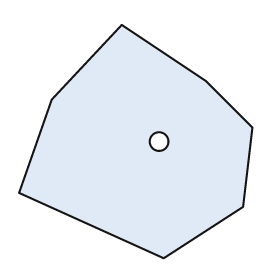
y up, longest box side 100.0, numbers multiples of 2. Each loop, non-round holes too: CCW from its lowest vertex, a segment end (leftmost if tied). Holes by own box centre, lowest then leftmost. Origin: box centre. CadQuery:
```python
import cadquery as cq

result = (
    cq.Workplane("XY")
    .moveTo(12.0, -50.0)
    .lineTo(46.0, -28.0)
    .lineTo(50.0, 6.0)
    .lineTo(30.0, 26.0)
    .lineTo(-6.0, 50.0)
    .lineTo(-36.0, 18.0)
    .lineTo(-50.0, -22.0)
    .close()
    .moveTo(10.0, 0.0)
    .circle(4.0)
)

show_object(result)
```